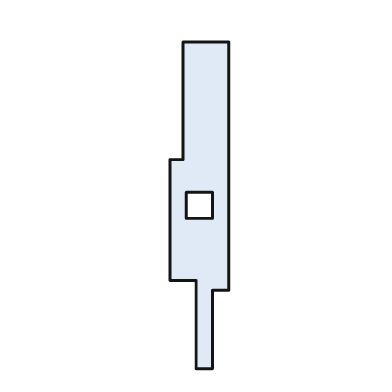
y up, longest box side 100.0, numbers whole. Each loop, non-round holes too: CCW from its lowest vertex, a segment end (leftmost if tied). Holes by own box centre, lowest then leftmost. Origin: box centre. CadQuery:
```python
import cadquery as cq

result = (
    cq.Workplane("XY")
    .moveTo(-1.0, -50.0)
    .lineTo(4.0, -50.0)
    .lineTo(4.0, -26.0)
    .lineTo(9.0, -26.0)
    .lineTo(9.0, 50.0)
    .lineTo(-5.0, 50.0)
    .lineTo(-5.0, 14.0)
    .lineTo(-9.0, 14.0)
    .lineTo(-9.0, -23.0)
    .lineTo(-1.0, -23.0)
    .close()
    .moveTo(-4.0, -4.0)
    .lineTo(4.0, -4.0)
    .lineTo(4.0, 4.0)
    .lineTo(-4.0, 4.0)
    .close()
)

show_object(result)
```